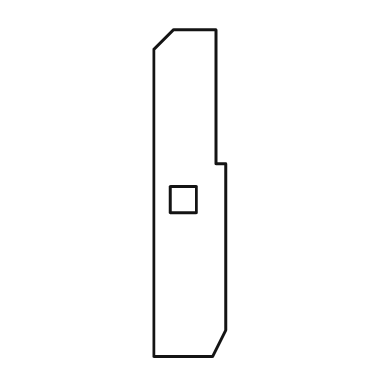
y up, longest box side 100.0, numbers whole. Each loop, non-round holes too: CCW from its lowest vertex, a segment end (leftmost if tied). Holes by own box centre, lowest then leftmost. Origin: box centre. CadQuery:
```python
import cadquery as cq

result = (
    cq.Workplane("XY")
    .moveTo(-11.0, -50.0)
    .lineTo(7.0, -50.0)
    .lineTo(11.0, -42.0)
    .lineTo(11.0, 9.0)
    .lineTo(8.0, 9.0)
    .lineTo(8.0, 50.0)
    .lineTo(-5.0, 50.0)
    .lineTo(-11.0, 44.0)
    .close()
    .moveTo(-6.0, -6.0)
    .lineTo(2.0, -6.0)
    .lineTo(2.0, 2.0)
    .lineTo(-6.0, 2.0)
    .close()
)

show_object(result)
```